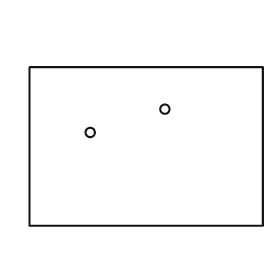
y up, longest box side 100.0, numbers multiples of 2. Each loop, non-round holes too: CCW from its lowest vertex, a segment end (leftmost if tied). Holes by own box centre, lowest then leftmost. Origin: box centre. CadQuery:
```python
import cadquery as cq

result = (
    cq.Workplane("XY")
    .moveTo(-50.0, -34.0)
    .lineTo(50.0, -34.0)
    .lineTo(50.0, 34.0)
    .lineTo(-50.0, 34.0)
    .close()
    .moveTo(-24.0, 6.0)
    .circle(2.0)
    .moveTo(8.0, 16.0)
    .circle(2.0)
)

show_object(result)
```